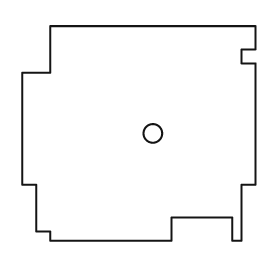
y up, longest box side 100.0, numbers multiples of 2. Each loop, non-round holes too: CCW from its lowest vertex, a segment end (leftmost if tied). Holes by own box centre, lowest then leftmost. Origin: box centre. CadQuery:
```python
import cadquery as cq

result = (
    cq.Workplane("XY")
    .moveTo(-38.0, -46.0)
    .lineTo(14.0, -46.0)
    .lineTo(14.0, -36.0)
    .lineTo(40.0, -36.0)
    .lineTo(40.0, -46.0)
    .lineTo(44.0, -46.0)
    .lineTo(44.0, -22.0)
    .lineTo(50.0, -22.0)
    .lineTo(50.0, 30.0)
    .lineTo(44.0, 30.0)
    .lineTo(44.0, 36.0)
    .lineTo(50.0, 36.0)
    .lineTo(50.0, 46.0)
    .lineTo(-38.0, 46.0)
    .lineTo(-38.0, 26.0)
    .lineTo(-50.0, 26.0)
    .lineTo(-50.0, -22.0)
    .lineTo(-44.0, -22.0)
    .lineTo(-44.0, -42.0)
    .lineTo(-38.0, -42.0)
    .close()
    .moveTo(6.0, 0.0)
    .circle(4.0)
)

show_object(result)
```